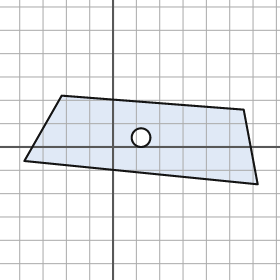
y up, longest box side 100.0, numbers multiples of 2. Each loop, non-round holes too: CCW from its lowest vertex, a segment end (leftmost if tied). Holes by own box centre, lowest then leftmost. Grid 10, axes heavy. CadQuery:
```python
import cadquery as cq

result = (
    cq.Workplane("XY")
    .moveTo(62.0, -16.0)
    .lineTo(56.0, 16.0)
    .lineTo(-22.0, 22.0)
    .lineTo(-38.0, -6.0)
    .close()
    .moveTo(12.0, 4.0)
    .circle(4.0)
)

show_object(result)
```